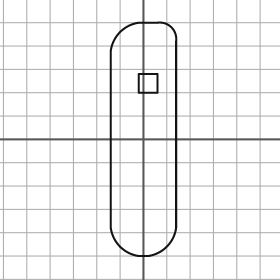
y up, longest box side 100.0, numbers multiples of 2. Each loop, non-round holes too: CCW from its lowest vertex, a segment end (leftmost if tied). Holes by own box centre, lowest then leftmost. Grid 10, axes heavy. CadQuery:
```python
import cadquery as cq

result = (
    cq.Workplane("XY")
    .moveTo(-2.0, -50.0)
    .lineTo(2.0, -50.0)
    .threePointArc((10.0, -46.0), (14.0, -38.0))
    .lineTo(14.0, 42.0)
    .threePointArc((12.0, 48.0), (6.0, 50.0))
    .lineTo(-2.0, 50.0)
    .threePointArc((-10.0, 46.0), (-14.0, 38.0))
    .lineTo(-14.0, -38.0)
    .threePointArc((-10.0, -46.0), (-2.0, -50.0))
    .close()
    .moveTo(-2.0, 20.0)
    .lineTo(6.0, 20.0)
    .lineTo(6.0, 28.0)
    .lineTo(-2.0, 28.0)
    .close()
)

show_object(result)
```